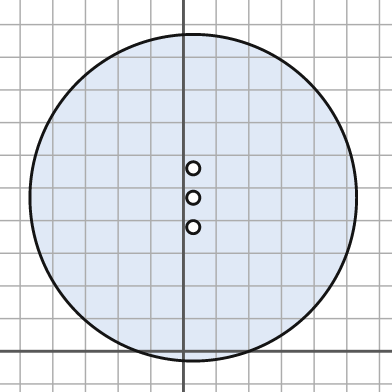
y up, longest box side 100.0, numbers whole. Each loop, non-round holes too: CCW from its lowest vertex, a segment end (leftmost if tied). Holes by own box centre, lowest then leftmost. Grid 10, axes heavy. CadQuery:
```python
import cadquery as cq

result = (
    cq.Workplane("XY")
    .moveTo(3.0, 47.0)
    .circle(50.0)
    .moveTo(3.0, 38.0)
    .circle(2.0)
    .moveTo(3.0, 47.0)
    .circle(2.0)
    .moveTo(3.0, 56.0)
    .circle(2.0)
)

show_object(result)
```